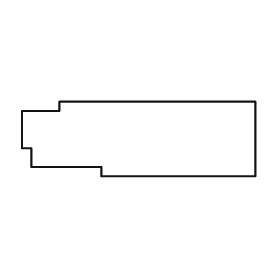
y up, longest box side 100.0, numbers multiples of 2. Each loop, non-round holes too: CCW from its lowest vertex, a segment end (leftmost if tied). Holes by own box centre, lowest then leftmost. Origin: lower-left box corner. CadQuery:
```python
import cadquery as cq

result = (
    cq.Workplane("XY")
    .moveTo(34.0, 0.0)
    .lineTo(100.0, 0.0)
    .lineTo(100.0, 32.0)
    .lineTo(16.0, 32.0)
    .lineTo(16.0, 28.0)
    .lineTo(0.0, 28.0)
    .lineTo(0.0, 12.0)
    .lineTo(4.0, 12.0)
    .lineTo(4.0, 4.0)
    .lineTo(34.0, 4.0)
    .close()
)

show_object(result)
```